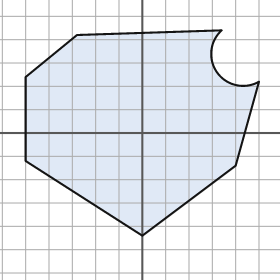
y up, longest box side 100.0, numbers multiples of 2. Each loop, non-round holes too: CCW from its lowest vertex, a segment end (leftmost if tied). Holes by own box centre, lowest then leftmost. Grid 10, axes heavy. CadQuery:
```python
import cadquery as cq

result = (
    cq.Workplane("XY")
    .moveTo(0.0, -44.0)
    .lineTo(40.0, -14.0)
    .lineTo(50.0, 22.0)
    .threePointArc((32.0, 26.0), (34.0, 44.0))
    .lineTo(-28.0, 42.0)
    .lineTo(-50.0, 24.0)
    .lineTo(-50.0, -12.0)
    .close()
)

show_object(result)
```